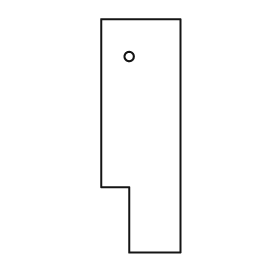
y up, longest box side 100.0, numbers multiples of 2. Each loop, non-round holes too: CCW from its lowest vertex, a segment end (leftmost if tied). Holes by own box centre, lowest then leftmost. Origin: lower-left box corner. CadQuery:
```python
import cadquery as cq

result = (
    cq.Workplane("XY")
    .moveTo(12.0, 0.0)
    .lineTo(34.0, 0.0)
    .lineTo(34.0, 100.0)
    .lineTo(0.0, 100.0)
    .lineTo(0.0, 28.0)
    .lineTo(12.0, 28.0)
    .close()
    .moveTo(12.0, 84.0)
    .circle(2.0)
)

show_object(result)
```